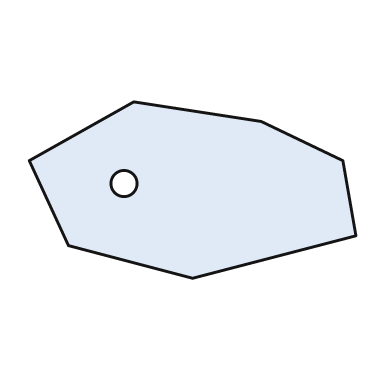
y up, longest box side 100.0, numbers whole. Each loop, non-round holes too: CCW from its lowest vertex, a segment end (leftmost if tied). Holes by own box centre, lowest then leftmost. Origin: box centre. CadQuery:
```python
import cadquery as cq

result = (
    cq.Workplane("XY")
    .moveTo(0.0, -27.0)
    .lineTo(50.0, -14.0)
    .lineTo(46.0, 9.0)
    .lineTo(21.0, 21.0)
    .lineTo(-18.0, 27.0)
    .lineTo(-50.0, 9.0)
    .lineTo(-38.0, -17.0)
    .close()
    .moveTo(-21.0, 2.0)
    .circle(4.0)
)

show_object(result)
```